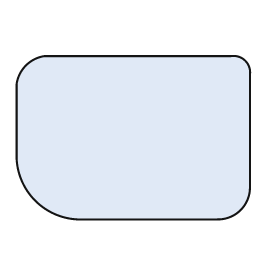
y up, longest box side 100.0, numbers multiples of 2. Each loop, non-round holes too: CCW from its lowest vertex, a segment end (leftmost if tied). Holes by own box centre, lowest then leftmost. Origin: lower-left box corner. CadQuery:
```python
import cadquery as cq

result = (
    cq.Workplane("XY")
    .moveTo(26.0, 0.0)
    .lineTo(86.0, 0.0)
    .threePointArc((96.0, 4.0), (100.0, 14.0))
    .lineTo(100.0, 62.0)
    .threePointArc((98.0, 68.0), (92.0, 70.0))
    .lineTo(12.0, 70.0)
    .threePointArc((4.0, 66.0), (0.0, 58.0))
    .lineTo(0.0, 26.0)
    .threePointArc((8.0, 8.0), (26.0, 0.0))
    .close()
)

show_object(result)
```